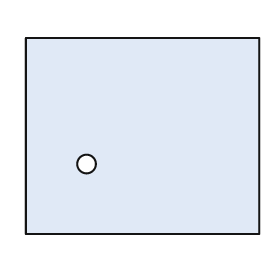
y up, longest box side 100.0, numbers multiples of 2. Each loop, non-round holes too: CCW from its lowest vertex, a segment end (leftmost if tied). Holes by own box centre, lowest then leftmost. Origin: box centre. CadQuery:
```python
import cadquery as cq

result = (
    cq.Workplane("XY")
    .moveTo(-50.0, -42.0)
    .lineTo(50.0, -42.0)
    .lineTo(50.0, 42.0)
    .lineTo(-50.0, 42.0)
    .close()
    .moveTo(-24.0, -12.0)
    .circle(4.0)
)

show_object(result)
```